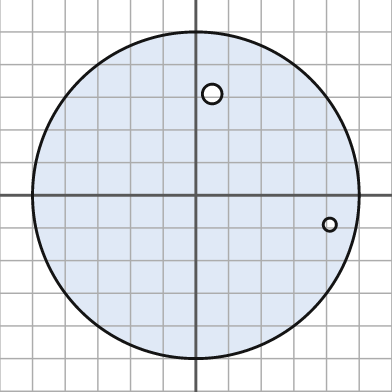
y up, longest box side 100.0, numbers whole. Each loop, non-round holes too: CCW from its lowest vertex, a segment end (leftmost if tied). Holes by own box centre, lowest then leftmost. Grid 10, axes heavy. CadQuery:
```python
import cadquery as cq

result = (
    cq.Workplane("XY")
    .moveTo(0.0, 0.0)
    .circle(50.0)
    .moveTo(41.0, -9.0)
    .circle(2.0)
    .moveTo(5.0, 31.0)
    .circle(3.0)
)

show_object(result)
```